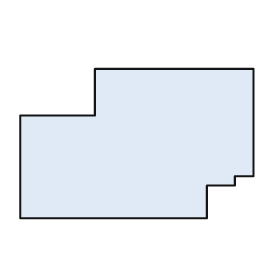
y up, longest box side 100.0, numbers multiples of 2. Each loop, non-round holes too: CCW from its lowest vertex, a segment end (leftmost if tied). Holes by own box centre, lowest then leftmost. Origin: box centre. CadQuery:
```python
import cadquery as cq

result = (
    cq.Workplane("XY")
    .moveTo(-50.0, -32.0)
    .lineTo(30.0, -32.0)
    .lineTo(30.0, -18.0)
    .lineTo(42.0, -18.0)
    .lineTo(42.0, -14.0)
    .lineTo(50.0, -14.0)
    .lineTo(50.0, 32.0)
    .lineTo(-18.0, 32.0)
    .lineTo(-18.0, 12.0)
    .lineTo(-50.0, 12.0)
    .close()
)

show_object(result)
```